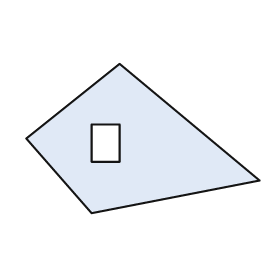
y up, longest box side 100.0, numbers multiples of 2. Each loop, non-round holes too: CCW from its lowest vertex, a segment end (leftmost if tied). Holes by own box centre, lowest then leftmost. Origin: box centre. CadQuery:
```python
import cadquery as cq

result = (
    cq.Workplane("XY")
    .moveTo(-22.0, -32.0)
    .lineTo(50.0, -18.0)
    .lineTo(-10.0, 32.0)
    .lineTo(-50.0, 0.0)
    .close()
    .moveTo(-22.0, -10.0)
    .lineTo(-10.0, -10.0)
    .lineTo(-10.0, 6.0)
    .lineTo(-22.0, 6.0)
    .close()
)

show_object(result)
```